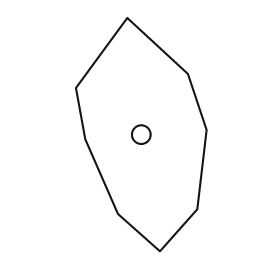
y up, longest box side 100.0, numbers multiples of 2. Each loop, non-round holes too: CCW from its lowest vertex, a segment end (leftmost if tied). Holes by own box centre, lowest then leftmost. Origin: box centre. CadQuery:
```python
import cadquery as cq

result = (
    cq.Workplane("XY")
    .moveTo(8.0, -50.0)
    .lineTo(24.0, -32.0)
    .lineTo(28.0, 2.0)
    .lineTo(20.0, 26.0)
    .lineTo(-6.0, 50.0)
    .lineTo(-28.0, 20.0)
    .lineTo(-24.0, -2.0)
    .lineTo(-10.0, -34.0)
    .close()
    .moveTo(0.0, 0.0)
    .circle(4.0)
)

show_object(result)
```